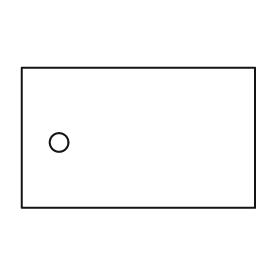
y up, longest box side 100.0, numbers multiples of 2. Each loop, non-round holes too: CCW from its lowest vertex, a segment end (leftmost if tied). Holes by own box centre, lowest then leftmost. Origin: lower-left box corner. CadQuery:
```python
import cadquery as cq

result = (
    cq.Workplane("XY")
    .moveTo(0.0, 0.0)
    .lineTo(100.0, 0.0)
    .lineTo(100.0, 60.0)
    .lineTo(0.0, 60.0)
    .close()
    .moveTo(16.0, 28.0)
    .circle(4.0)
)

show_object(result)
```